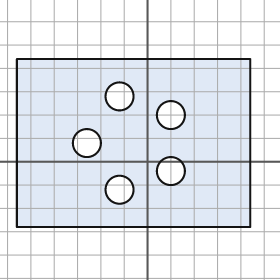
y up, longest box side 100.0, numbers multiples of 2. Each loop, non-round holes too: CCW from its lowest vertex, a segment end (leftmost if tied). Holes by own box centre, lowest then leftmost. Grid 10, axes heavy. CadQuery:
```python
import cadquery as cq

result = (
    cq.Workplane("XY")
    .moveTo(-56.0, -28.0)
    .lineTo(44.0, -28.0)
    .lineTo(44.0, 44.0)
    .lineTo(-56.0, 44.0)
    .close()
    .moveTo(-12.0, -12.0)
    .circle(6.0)
    .moveTo(10.0, -4.0)
    .circle(6.0)
    .moveTo(-26.0, 8.0)
    .circle(6.0)
    .moveTo(10.0, 20.0)
    .circle(6.0)
    .moveTo(-12.0, 28.0)
    .circle(6.0)
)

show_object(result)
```